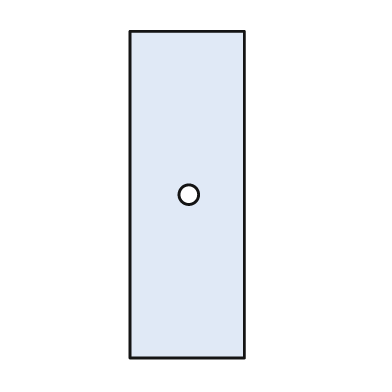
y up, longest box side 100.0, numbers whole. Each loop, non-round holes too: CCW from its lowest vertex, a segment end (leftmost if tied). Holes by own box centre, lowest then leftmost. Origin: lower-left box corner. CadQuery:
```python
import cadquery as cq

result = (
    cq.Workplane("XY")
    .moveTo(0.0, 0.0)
    .lineTo(35.0, 0.0)
    .lineTo(35.0, 100.0)
    .lineTo(0.0, 100.0)
    .close()
    .moveTo(18.0, 50.0)
    .circle(3.0)
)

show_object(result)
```